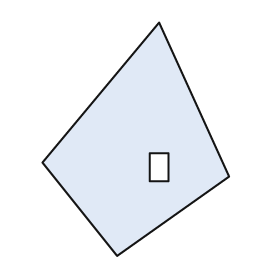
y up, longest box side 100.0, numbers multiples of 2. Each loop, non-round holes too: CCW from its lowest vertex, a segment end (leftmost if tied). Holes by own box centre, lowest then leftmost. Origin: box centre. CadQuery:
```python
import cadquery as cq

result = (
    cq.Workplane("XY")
    .moveTo(-8.0, -50.0)
    .lineTo(40.0, -16.0)
    .lineTo(10.0, 50.0)
    .lineTo(-40.0, -10.0)
    .close()
    .moveTo(6.0, -18.0)
    .lineTo(14.0, -18.0)
    .lineTo(14.0, -6.0)
    .lineTo(6.0, -6.0)
    .close()
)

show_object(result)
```